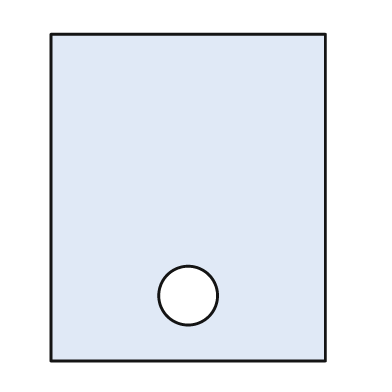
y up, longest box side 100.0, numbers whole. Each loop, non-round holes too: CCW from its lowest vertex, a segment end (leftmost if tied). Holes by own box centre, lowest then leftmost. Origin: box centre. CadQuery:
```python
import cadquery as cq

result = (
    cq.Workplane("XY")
    .moveTo(-42.0, -50.0)
    .lineTo(42.0, -50.0)
    .lineTo(42.0, 50.0)
    .lineTo(-42.0, 50.0)
    .close()
    .moveTo(0.0, -30.0)
    .circle(9.0)
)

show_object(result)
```